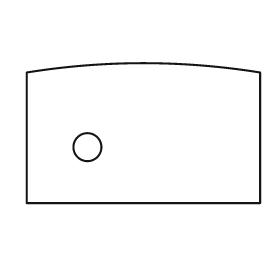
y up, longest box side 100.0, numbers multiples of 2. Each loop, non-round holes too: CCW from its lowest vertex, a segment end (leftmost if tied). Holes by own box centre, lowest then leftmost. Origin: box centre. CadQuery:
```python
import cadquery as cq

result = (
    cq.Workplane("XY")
    .moveTo(-50.0, -30.0)
    .lineTo(50.0, -30.0)
    .lineTo(50.0, 26.0)
    .threePointArc((0.0, 30.0), (-50.0, 26.0))
    .close()
    .moveTo(-24.0, -6.0)
    .circle(6.0)
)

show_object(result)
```